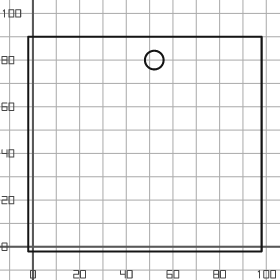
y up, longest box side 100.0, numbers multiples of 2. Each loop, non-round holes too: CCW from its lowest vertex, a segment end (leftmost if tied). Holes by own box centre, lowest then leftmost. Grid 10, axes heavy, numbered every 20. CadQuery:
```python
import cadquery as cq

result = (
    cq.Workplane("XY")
    .moveTo(-2.0, -2.0)
    .lineTo(98.0, -2.0)
    .lineTo(98.0, 90.0)
    .lineTo(-2.0, 90.0)
    .close()
    .moveTo(52.0, 80.0)
    .circle(4.0)
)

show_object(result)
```